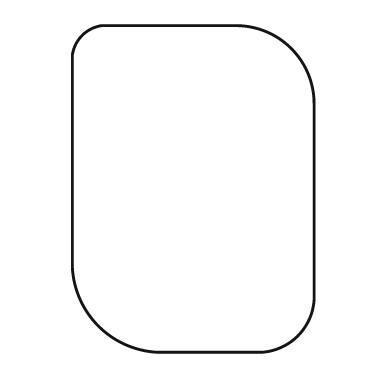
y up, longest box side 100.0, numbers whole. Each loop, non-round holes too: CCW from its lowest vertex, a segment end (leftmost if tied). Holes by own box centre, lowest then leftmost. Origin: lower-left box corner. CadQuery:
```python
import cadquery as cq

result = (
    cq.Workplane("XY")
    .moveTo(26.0, 0.0)
    .lineTo(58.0, 0.0)
    .threePointArc((69.0, 5.0), (74.0, 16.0))
    .lineTo(74.0, 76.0)
    .threePointArc((67.0, 93.0), (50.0, 100.0))
    .lineTo(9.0, 100.0)
    .threePointArc((3.0, 97.0), (0.0, 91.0))
    .lineTo(0.0, 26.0)
    .threePointArc((8.0, 8.0), (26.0, 0.0))
    .close()
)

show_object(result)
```